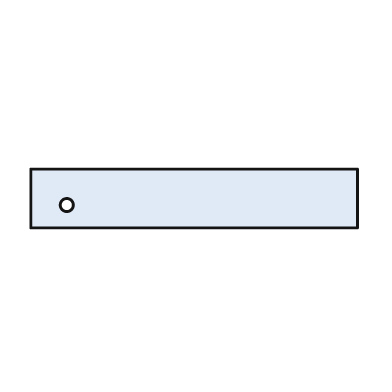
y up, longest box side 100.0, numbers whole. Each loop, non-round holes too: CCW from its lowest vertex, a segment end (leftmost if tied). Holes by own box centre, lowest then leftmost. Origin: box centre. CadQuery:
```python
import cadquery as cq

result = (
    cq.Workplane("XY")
    .moveTo(-50.0, -9.0)
    .lineTo(50.0, -9.0)
    .lineTo(50.0, 9.0)
    .lineTo(-50.0, 9.0)
    .close()
    .moveTo(-39.0, -2.0)
    .circle(2.0)
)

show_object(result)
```